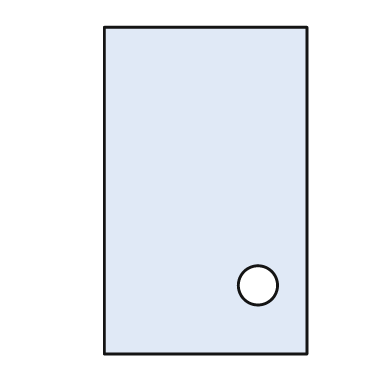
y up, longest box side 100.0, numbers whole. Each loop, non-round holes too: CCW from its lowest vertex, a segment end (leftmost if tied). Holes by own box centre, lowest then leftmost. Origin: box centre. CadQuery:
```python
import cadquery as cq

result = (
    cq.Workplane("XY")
    .moveTo(-31.0, -50.0)
    .lineTo(31.0, -50.0)
    .lineTo(31.0, 50.0)
    .lineTo(-31.0, 50.0)
    .close()
    .moveTo(16.0, -29.0)
    .circle(6.0)
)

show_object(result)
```